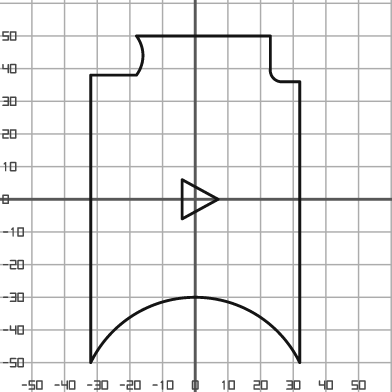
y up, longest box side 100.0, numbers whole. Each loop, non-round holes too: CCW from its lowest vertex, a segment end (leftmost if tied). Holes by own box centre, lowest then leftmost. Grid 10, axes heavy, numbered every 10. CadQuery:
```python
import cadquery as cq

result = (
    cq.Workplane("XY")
    .moveTo(-32.0, -50.0)
    .threePointArc((0.0, -30.0), (32.0, -50.0))
    .lineTo(32.0, 36.0)
    .lineTo(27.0, 36.0)
    .threePointArc((24.0, 37.0), (23.0, 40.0))
    .lineTo(23.0, 50.0)
    .lineTo(-18.0, 50.0)
    .threePointArc((-16.0, 44.0), (-18.0, 38.0))
    .lineTo(-32.0, 38.0)
    .close()
    .moveTo(-4.0, -6.0)
    .lineTo(7.0, 0.0)
    .lineTo(-4.0, 6.0)
    .close()
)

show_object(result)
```